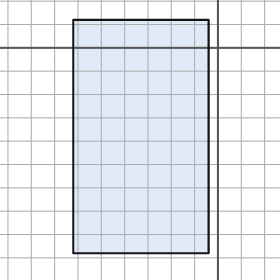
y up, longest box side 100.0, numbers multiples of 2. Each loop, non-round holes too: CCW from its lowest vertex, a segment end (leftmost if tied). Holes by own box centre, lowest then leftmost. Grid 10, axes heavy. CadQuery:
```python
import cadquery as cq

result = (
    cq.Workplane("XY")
    .moveTo(-62.0, -88.0)
    .lineTo(-4.0, -88.0)
    .lineTo(-4.0, 12.0)
    .lineTo(-62.0, 12.0)
    .close()
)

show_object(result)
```